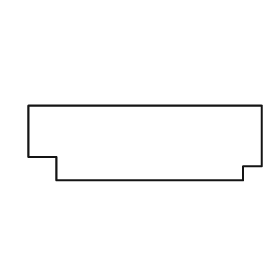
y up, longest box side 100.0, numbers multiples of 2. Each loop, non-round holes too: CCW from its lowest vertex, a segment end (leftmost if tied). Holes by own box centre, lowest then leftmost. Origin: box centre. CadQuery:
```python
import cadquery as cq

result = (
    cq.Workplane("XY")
    .moveTo(-38.0, -16.0)
    .lineTo(42.0, -16.0)
    .lineTo(42.0, -10.0)
    .lineTo(50.0, -10.0)
    .lineTo(50.0, 16.0)
    .lineTo(-50.0, 16.0)
    .lineTo(-50.0, -6.0)
    .lineTo(-38.0, -6.0)
    .close()
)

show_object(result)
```